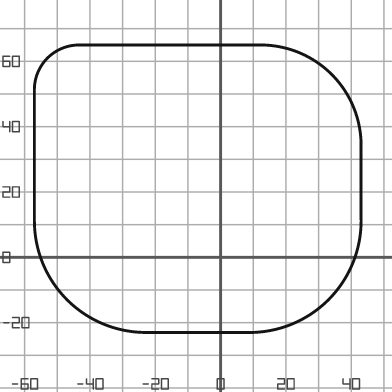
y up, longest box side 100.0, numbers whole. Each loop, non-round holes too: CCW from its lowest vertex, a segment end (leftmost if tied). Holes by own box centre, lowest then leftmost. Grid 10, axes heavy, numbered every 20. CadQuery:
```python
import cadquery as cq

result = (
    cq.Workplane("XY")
    .moveTo(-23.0, -23.0)
    .lineTo(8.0, -23.0)
    .threePointArc((33.0, -13.0), (43.0, 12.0))
    .lineTo(43.0, 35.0)
    .threePointArc((34.0, 56.0), (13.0, 65.0))
    .lineTo(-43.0, 65.0)
    .threePointArc((-53.0, 61.0), (-57.0, 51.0))
    .lineTo(-57.0, 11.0)
    .threePointArc((-47.0, -13.0), (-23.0, -23.0))
    .close()
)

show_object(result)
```